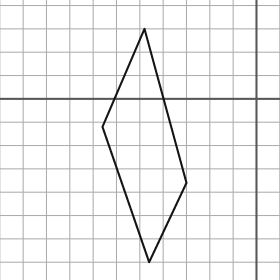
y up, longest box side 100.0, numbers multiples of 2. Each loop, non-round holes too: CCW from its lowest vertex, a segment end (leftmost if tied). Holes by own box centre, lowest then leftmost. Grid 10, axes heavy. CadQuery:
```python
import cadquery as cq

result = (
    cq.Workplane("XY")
    .moveTo(-46.0, -70.0)
    .lineTo(-30.0, -36.0)
    .lineTo(-48.0, 30.0)
    .lineTo(-66.0, -12.0)
    .close()
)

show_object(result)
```